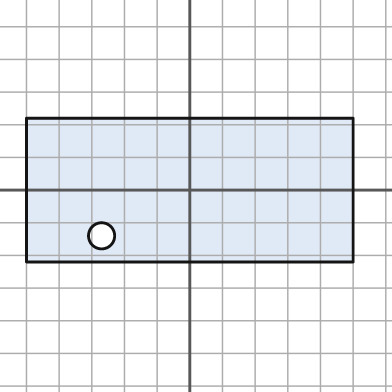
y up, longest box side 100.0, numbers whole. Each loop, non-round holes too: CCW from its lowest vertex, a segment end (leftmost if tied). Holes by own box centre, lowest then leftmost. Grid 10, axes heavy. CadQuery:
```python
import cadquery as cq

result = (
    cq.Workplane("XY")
    .moveTo(-50.0, -22.0)
    .lineTo(50.0, -22.0)
    .lineTo(50.0, 22.0)
    .lineTo(-50.0, 22.0)
    .close()
    .moveTo(-27.0, -14.0)
    .circle(4.0)
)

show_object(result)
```